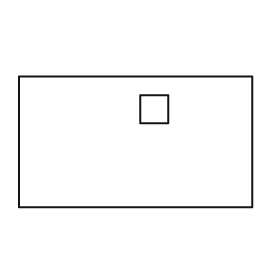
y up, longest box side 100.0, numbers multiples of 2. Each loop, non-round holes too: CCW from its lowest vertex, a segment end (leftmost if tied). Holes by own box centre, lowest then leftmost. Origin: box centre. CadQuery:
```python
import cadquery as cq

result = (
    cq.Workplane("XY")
    .moveTo(-50.0, -28.0)
    .lineTo(50.0, -28.0)
    .lineTo(50.0, 28.0)
    .lineTo(-50.0, 28.0)
    .close()
    .moveTo(2.0, 8.0)
    .lineTo(14.0, 8.0)
    .lineTo(14.0, 20.0)
    .lineTo(2.0, 20.0)
    .close()
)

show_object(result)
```